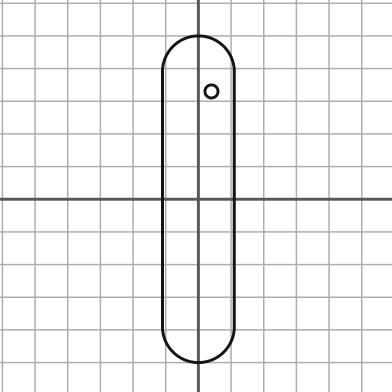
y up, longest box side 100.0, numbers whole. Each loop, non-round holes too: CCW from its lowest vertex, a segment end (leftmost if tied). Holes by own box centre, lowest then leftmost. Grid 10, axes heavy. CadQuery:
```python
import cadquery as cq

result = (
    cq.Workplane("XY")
    .moveTo(-11.0, -39.0)
    .threePointArc((0.0, -50.0), (11.0, -39.0))
    .lineTo(11.0, 39.0)
    .threePointArc((0.0, 50.0), (-11.0, 39.0))
    .close()
    .moveTo(4.0, 33.0)
    .circle(2.0)
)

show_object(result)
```